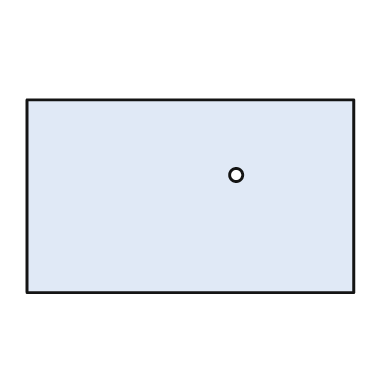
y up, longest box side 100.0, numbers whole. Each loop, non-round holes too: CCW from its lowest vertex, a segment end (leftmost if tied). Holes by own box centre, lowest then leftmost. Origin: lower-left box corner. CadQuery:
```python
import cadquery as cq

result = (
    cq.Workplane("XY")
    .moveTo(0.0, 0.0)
    .lineTo(100.0, 0.0)
    .lineTo(100.0, 59.0)
    .lineTo(0.0, 59.0)
    .close()
    .moveTo(64.0, 36.0)
    .circle(2.0)
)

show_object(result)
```